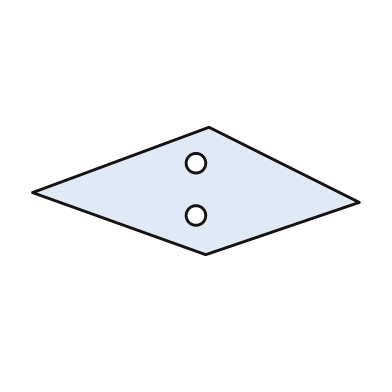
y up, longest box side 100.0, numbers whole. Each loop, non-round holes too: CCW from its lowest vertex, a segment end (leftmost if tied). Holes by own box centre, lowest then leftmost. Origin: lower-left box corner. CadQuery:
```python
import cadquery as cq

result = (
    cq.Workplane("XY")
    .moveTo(53.0, 0.0)
    .lineTo(100.0, 16.0)
    .lineTo(54.0, 39.0)
    .lineTo(0.0, 19.0)
    .close()
    .moveTo(50.0, 12.0)
    .circle(3.0)
    .moveTo(50.0, 28.0)
    .circle(3.0)
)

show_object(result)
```